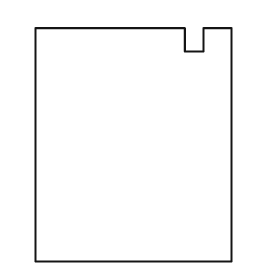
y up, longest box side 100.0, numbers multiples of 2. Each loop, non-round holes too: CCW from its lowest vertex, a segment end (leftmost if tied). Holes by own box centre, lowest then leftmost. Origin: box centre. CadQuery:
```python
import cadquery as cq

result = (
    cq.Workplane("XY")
    .moveTo(-42.0, -50.0)
    .lineTo(42.0, -50.0)
    .lineTo(42.0, 50.0)
    .lineTo(30.0, 50.0)
    .lineTo(30.0, 40.0)
    .lineTo(22.0, 40.0)
    .lineTo(22.0, 50.0)
    .lineTo(-42.0, 50.0)
    .close()
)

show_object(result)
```